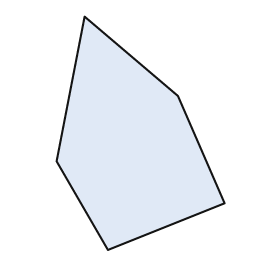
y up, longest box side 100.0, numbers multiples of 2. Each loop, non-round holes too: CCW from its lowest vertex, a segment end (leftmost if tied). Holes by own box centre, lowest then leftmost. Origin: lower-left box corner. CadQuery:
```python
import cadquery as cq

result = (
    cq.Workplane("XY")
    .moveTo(22.0, 0.0)
    .lineTo(72.0, 20.0)
    .lineTo(52.0, 66.0)
    .lineTo(12.0, 100.0)
    .lineTo(0.0, 38.0)
    .close()
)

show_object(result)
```